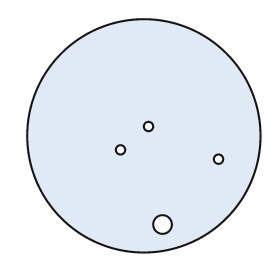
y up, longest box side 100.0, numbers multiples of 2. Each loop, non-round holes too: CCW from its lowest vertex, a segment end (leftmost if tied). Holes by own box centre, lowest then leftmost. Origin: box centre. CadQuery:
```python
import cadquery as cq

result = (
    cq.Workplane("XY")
    .moveTo(0.0, 0.0)
    .circle(50.0)
    .moveTo(8.0, -38.0)
    .circle(4.0)
    .moveTo(32.0, -10.0)
    .circle(2.0)
    .moveTo(-10.0, -6.0)
    .circle(2.0)
    .moveTo(2.0, 4.0)
    .circle(2.0)
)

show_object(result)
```